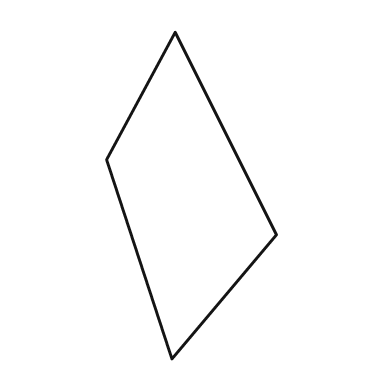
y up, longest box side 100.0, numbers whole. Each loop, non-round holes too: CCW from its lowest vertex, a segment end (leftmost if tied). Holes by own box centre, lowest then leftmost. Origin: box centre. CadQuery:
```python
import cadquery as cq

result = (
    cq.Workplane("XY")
    .moveTo(-6.0, -50.0)
    .lineTo(26.0, -12.0)
    .lineTo(-5.0, 50.0)
    .lineTo(-26.0, 11.0)
    .close()
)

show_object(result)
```